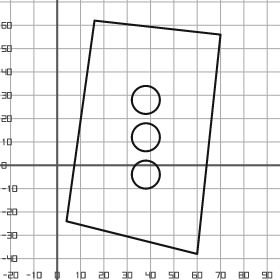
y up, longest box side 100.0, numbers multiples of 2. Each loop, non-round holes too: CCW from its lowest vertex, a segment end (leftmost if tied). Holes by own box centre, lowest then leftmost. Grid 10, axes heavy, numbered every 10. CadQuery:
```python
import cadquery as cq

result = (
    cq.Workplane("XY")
    .moveTo(60.0, -38.0)
    .lineTo(70.0, 56.0)
    .lineTo(16.0, 62.0)
    .lineTo(4.0, -24.0)
    .close()
    .moveTo(38.0, -4.0)
    .circle(6.0)
    .moveTo(38.0, 12.0)
    .circle(6.0)
    .moveTo(38.0, 28.0)
    .circle(6.0)
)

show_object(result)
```